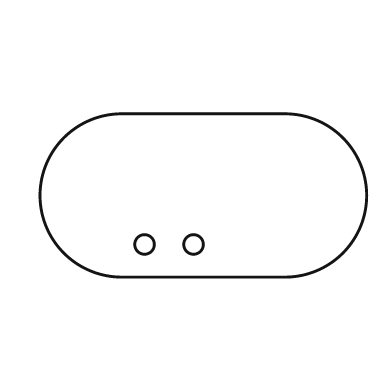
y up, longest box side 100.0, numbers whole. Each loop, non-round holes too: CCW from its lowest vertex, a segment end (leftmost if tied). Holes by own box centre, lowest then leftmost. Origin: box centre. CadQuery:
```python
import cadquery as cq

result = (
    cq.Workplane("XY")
    .moveTo(-25.0, -25.0)
    .lineTo(25.0, -25.0)
    .threePointArc((50.0, 0.0), (25.0, 25.0))
    .lineTo(-25.0, 25.0)
    .threePointArc((-50.0, 0.0), (-25.0, -25.0))
    .close()
    .moveTo(-18.0, -15.0)
    .circle(3.0)
    .moveTo(-3.0, -15.0)
    .circle(3.0)
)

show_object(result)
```